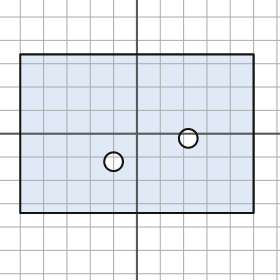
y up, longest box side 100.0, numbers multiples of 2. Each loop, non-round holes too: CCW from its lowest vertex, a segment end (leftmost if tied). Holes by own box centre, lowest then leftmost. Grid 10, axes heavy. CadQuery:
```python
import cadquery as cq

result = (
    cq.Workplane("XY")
    .moveTo(-50.0, -34.0)
    .lineTo(50.0, -34.0)
    .lineTo(50.0, 34.0)
    .lineTo(-50.0, 34.0)
    .close()
    .moveTo(-10.0, -12.0)
    .circle(4.0)
    .moveTo(22.0, -2.0)
    .circle(4.0)
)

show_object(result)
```